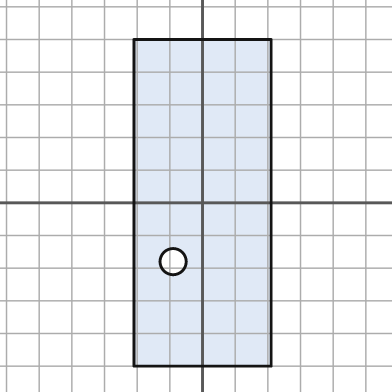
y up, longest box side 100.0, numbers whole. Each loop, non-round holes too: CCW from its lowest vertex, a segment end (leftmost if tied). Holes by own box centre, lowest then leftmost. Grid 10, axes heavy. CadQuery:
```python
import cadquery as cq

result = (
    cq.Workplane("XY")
    .moveTo(-21.0, -50.0)
    .lineTo(21.0, -50.0)
    .lineTo(21.0, 50.0)
    .lineTo(-21.0, 50.0)
    .close()
    .moveTo(-9.0, -18.0)
    .circle(4.0)
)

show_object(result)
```